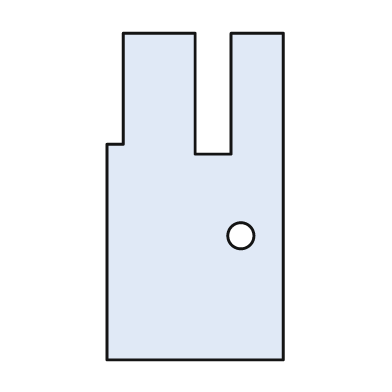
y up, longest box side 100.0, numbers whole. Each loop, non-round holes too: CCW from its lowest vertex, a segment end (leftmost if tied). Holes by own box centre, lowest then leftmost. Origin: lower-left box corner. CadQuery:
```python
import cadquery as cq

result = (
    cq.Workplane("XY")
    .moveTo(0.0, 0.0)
    .lineTo(54.0, 0.0)
    .lineTo(54.0, 100.0)
    .lineTo(38.0, 100.0)
    .lineTo(38.0, 63.0)
    .lineTo(27.0, 63.0)
    .lineTo(27.0, 100.0)
    .lineTo(5.0, 100.0)
    .lineTo(5.0, 66.0)
    .lineTo(0.0, 66.0)
    .close()
    .moveTo(41.0, 38.0)
    .circle(4.0)
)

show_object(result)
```